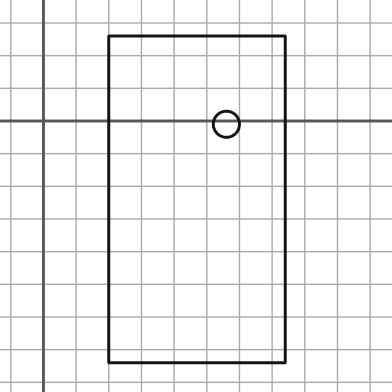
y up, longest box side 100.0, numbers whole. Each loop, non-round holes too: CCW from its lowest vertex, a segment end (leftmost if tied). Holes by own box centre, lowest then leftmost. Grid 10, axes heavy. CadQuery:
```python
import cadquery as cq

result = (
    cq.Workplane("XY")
    .moveTo(20.0, -74.0)
    .lineTo(74.0, -74.0)
    .lineTo(74.0, 26.0)
    .lineTo(20.0, 26.0)
    .close()
    .moveTo(56.0, -1.0)
    .circle(4.0)
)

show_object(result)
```